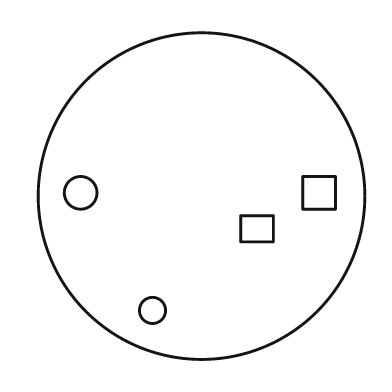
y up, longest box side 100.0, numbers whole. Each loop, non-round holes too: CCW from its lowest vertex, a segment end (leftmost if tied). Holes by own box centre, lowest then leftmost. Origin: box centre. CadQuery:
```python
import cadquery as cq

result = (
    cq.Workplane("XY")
    .moveTo(0.0, 0.0)
    .circle(50.0)
    .moveTo(-15.0, -35.0)
    .circle(4.0)
    .moveTo(12.0, -14.0)
    .lineTo(22.0, -14.0)
    .lineTo(22.0, -6.0)
    .lineTo(12.0, -6.0)
    .close()
    .moveTo(-37.0, 1.0)
    .circle(5.0)
    .moveTo(31.0, -4.0)
    .lineTo(41.0, -4.0)
    .lineTo(41.0, 6.0)
    .lineTo(31.0, 6.0)
    .close()
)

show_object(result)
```